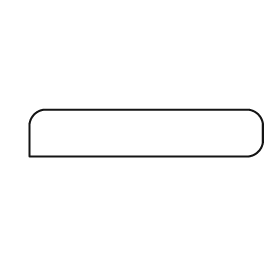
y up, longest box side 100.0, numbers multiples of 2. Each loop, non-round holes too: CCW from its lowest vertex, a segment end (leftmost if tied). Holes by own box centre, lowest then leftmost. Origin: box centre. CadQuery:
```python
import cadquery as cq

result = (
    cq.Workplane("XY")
    .moveTo(-50.0, -10.0)
    .lineTo(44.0, -10.0)
    .threePointArc((48.0, -8.0), (50.0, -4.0))
    .lineTo(50.0, 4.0)
    .threePointArc((48.0, 8.0), (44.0, 10.0))
    .lineTo(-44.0, 10.0)
    .threePointArc((-48.0, 8.0), (-50.0, 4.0))
    .close()
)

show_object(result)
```